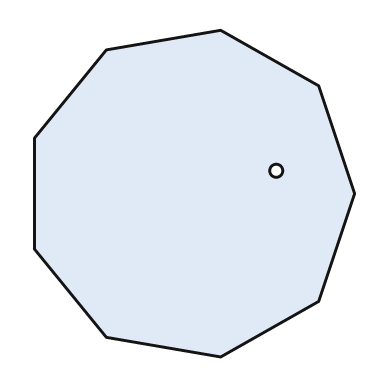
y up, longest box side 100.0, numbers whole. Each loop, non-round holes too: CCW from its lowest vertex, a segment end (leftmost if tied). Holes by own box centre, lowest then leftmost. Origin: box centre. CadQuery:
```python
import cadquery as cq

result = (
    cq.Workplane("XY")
    .moveTo(8.0, -50.0)
    .lineTo(38.0, -33.0)
    .lineTo(49.0, 0.0)
    .lineTo(38.0, 33.0)
    .lineTo(8.0, 50.0)
    .lineTo(-27.0, 44.0)
    .lineTo(-49.0, 17.0)
    .lineTo(-49.0, -17.0)
    .lineTo(-27.0, -44.0)
    .close()
    .moveTo(25.0, 7.0)
    .circle(2.0)
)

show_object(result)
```